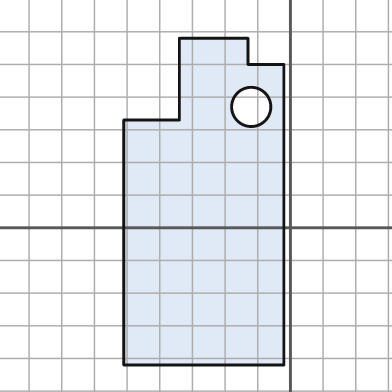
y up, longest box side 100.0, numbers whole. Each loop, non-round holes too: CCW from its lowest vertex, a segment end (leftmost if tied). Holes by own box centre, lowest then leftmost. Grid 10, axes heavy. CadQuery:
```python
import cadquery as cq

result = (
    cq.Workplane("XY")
    .moveTo(-51.0, -42.0)
    .lineTo(-2.0, -42.0)
    .lineTo(-2.0, 50.0)
    .lineTo(-13.0, 50.0)
    .lineTo(-13.0, 58.0)
    .lineTo(-34.0, 58.0)
    .lineTo(-34.0, 33.0)
    .lineTo(-51.0, 33.0)
    .close()
    .moveTo(-12.0, 37.0)
    .circle(6.0)
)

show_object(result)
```